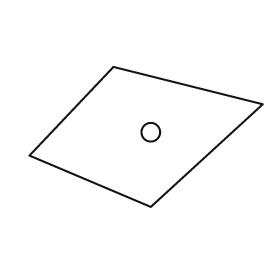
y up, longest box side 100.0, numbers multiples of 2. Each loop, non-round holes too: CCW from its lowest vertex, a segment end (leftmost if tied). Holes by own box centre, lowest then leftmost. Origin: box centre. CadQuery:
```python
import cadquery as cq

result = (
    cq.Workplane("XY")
    .moveTo(2.0, -30.0)
    .lineTo(50.0, 14.0)
    .lineTo(-14.0, 30.0)
    .lineTo(-50.0, -8.0)
    .close()
    .moveTo(2.0, 2.0)
    .circle(4.0)
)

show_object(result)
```